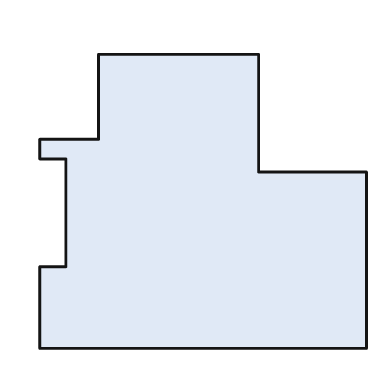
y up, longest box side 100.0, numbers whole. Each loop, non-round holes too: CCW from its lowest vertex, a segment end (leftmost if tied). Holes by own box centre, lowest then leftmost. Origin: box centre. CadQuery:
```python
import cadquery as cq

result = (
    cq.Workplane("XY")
    .moveTo(-50.0, -45.0)
    .lineTo(50.0, -45.0)
    .lineTo(50.0, 9.0)
    .lineTo(17.0, 9.0)
    .lineTo(17.0, 45.0)
    .lineTo(-32.0, 45.0)
    .lineTo(-32.0, 19.0)
    .lineTo(-50.0, 19.0)
    .lineTo(-50.0, 13.0)
    .lineTo(-42.0, 13.0)
    .lineTo(-42.0, -20.0)
    .lineTo(-50.0, -20.0)
    .close()
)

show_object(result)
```